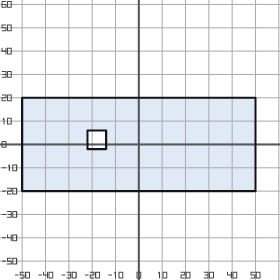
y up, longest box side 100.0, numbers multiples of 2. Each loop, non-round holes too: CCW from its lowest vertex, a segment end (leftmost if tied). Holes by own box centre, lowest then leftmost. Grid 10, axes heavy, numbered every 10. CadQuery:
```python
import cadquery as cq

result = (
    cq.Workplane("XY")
    .moveTo(-50.0, -20.0)
    .lineTo(50.0, -20.0)
    .lineTo(50.0, 20.0)
    .lineTo(-50.0, 20.0)
    .close()
    .moveTo(-22.0, -2.0)
    .lineTo(-14.0, -2.0)
    .lineTo(-14.0, 6.0)
    .lineTo(-22.0, 6.0)
    .close()
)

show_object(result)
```